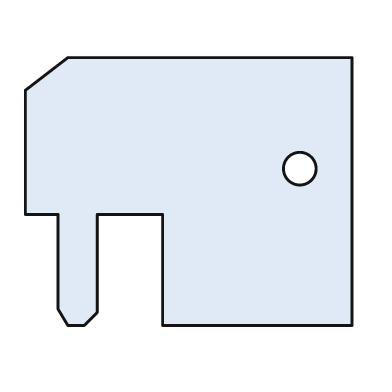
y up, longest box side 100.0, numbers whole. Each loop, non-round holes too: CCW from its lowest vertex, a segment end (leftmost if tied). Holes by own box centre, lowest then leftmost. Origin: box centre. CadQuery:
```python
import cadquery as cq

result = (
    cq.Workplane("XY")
    .moveTo(-37.0, -41.0)
    .lineTo(-32.0, -41.0)
    .lineTo(-28.0, -37.0)
    .lineTo(-28.0, -7.0)
    .lineTo(-8.0, -7.0)
    .lineTo(-8.0, -41.0)
    .lineTo(50.0, -41.0)
    .lineTo(50.0, 41.0)
    .lineTo(-37.0, 41.0)
    .lineTo(-50.0, 31.0)
    .lineTo(-50.0, -7.0)
    .lineTo(-40.0, -7.0)
    .lineTo(-40.0, -36.0)
    .close()
    .moveTo(34.0, 7.0)
    .circle(5.0)
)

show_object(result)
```